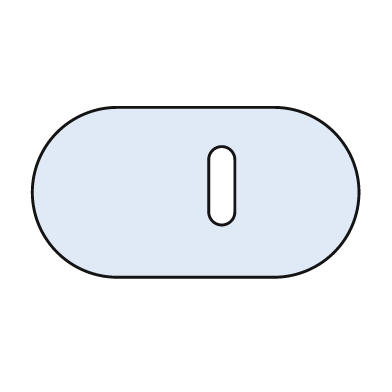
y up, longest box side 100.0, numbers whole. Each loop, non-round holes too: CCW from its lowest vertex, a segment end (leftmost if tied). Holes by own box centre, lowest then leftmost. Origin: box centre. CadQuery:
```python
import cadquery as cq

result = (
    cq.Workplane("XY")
    .moveTo(-24.0, -26.0)
    .lineTo(24.0, -26.0)
    .threePointArc((50.0, 0.0), (24.0, 26.0))
    .lineTo(-24.0, 26.0)
    .threePointArc((-50.0, 0.0), (-24.0, -26.0))
    .close()
    .moveTo(4.0, -6.0)
    .threePointArc((8.0, -10.0), (12.0, -6.0))
    .lineTo(12.0, 10.0)
    .threePointArc((8.0, 14.0), (4.0, 10.0))
    .close()
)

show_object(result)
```